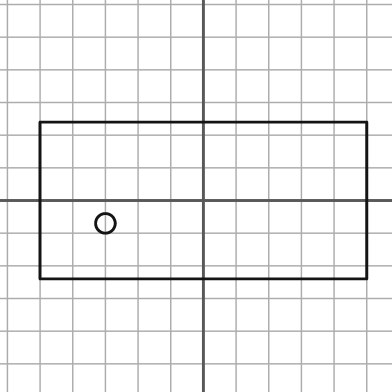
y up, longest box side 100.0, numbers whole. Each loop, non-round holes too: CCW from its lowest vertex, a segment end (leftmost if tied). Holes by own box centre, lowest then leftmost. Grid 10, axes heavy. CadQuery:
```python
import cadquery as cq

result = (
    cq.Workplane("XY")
    .moveTo(-50.0, -24.0)
    .lineTo(50.0, -24.0)
    .lineTo(50.0, 24.0)
    .lineTo(-50.0, 24.0)
    .close()
    .moveTo(-30.0, -7.0)
    .circle(3.0)
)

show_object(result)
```